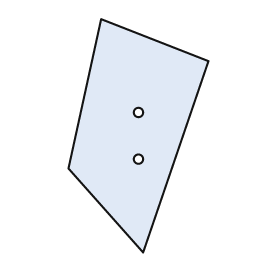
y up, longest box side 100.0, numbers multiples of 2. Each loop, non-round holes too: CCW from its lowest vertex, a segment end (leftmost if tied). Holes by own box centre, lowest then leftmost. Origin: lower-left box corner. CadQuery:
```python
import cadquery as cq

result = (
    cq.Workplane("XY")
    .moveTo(32.0, 0.0)
    .lineTo(60.0, 82.0)
    .lineTo(14.0, 100.0)
    .lineTo(0.0, 36.0)
    .close()
    .moveTo(30.0, 40.0)
    .circle(2.0)
    .moveTo(30.0, 60.0)
    .circle(2.0)
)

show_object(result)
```